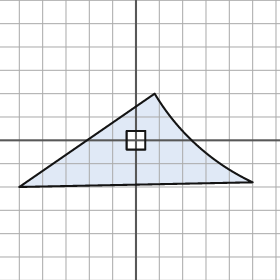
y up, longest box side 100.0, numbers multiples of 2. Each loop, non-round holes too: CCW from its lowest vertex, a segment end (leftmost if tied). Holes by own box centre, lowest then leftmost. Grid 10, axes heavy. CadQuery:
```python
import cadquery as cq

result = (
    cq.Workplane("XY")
    .moveTo(-50.0, -20.0)
    .lineTo(50.0, -18.0)
    .threePointArc((26.0, -2.0), (8.0, 20.0))
    .close()
    .moveTo(-4.0, -4.0)
    .lineTo(4.0, -4.0)
    .lineTo(4.0, 4.0)
    .lineTo(-4.0, 4.0)
    .close()
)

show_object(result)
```